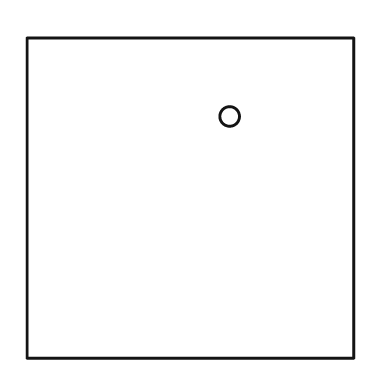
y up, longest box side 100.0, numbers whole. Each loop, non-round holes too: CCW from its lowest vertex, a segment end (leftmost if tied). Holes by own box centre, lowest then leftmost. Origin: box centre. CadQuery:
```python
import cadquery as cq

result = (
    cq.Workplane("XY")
    .moveTo(-50.0, -49.0)
    .lineTo(50.0, -49.0)
    .lineTo(50.0, 49.0)
    .lineTo(-50.0, 49.0)
    .close()
    .moveTo(12.0, 25.0)
    .circle(3.0)
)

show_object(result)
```